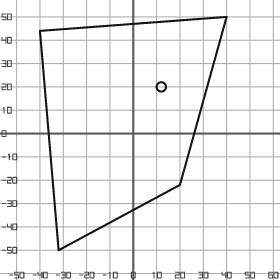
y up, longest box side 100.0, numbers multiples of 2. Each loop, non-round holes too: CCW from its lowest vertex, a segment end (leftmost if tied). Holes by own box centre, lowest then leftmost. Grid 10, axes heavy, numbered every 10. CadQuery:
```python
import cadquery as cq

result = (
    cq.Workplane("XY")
    .moveTo(-32.0, -50.0)
    .lineTo(20.0, -22.0)
    .lineTo(40.0, 50.0)
    .lineTo(-40.0, 44.0)
    .close()
    .moveTo(12.0, 20.0)
    .circle(2.0)
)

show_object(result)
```